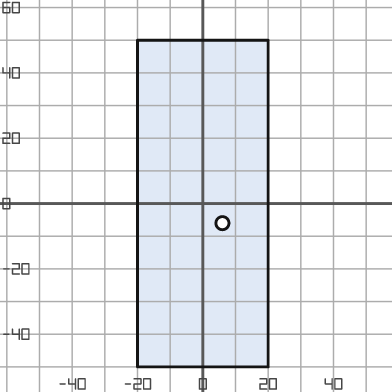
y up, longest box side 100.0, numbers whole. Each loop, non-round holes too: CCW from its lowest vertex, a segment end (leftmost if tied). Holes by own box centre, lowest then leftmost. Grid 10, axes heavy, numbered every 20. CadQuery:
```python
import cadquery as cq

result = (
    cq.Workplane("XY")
    .moveTo(-20.0, -50.0)
    .lineTo(20.0, -50.0)
    .lineTo(20.0, 50.0)
    .lineTo(-20.0, 50.0)
    .close()
    .moveTo(6.0, -6.0)
    .circle(2.0)
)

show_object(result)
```